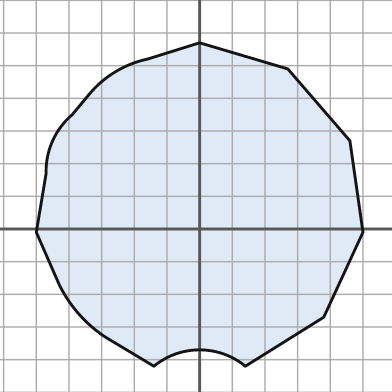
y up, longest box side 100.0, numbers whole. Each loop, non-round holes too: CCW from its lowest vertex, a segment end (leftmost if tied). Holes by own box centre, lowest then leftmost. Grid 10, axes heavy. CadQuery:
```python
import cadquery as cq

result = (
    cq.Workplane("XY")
    .moveTo(-14.0, -42.0)
    .threePointArc((0.0, -37.0), (14.0, -42.0))
    .lineTo(38.0, -27.0)
    .lineTo(50.0, -1.0)
    .lineTo(46.0, 27.0)
    .lineTo(27.0, 49.0)
    .lineTo(0.0, 57.0)
    .lineTo(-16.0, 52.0)
    .threePointArc((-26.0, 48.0), (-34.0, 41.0))
    .lineTo(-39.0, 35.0)
    .threePointArc((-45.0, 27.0), (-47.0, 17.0))
    .lineTo(-50.0, -1.0)
    .lineTo(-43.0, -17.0)
    .threePointArc((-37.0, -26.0), (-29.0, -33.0))
    .close()
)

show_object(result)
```